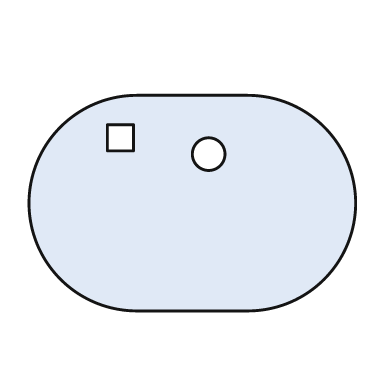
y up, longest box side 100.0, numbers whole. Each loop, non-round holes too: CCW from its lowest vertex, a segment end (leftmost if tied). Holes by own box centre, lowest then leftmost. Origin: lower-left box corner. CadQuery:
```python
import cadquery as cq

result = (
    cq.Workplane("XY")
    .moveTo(33.0, 0.0)
    .lineTo(67.0, 0.0)
    .threePointArc((100.0, 33.0), (67.0, 66.0))
    .lineTo(33.0, 66.0)
    .threePointArc((0.0, 33.0), (33.0, 0.0))
    .close()
    .moveTo(55.0, 48.0)
    .circle(5.0)
    .moveTo(24.0, 49.0)
    .lineTo(32.0, 49.0)
    .lineTo(32.0, 57.0)
    .lineTo(24.0, 57.0)
    .close()
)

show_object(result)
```